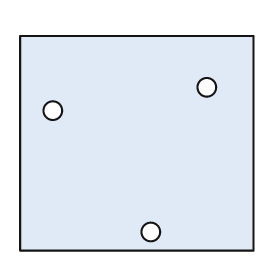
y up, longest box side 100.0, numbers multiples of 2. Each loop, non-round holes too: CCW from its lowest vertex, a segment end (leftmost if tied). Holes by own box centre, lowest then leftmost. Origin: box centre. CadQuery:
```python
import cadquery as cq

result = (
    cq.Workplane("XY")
    .moveTo(-50.0, -46.0)
    .lineTo(50.0, -46.0)
    .lineTo(50.0, 46.0)
    .lineTo(-50.0, 46.0)
    .close()
    .moveTo(6.0, -38.0)
    .circle(4.0)
    .moveTo(-36.0, 14.0)
    .circle(4.0)
    .moveTo(30.0, 24.0)
    .circle(4.0)
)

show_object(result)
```